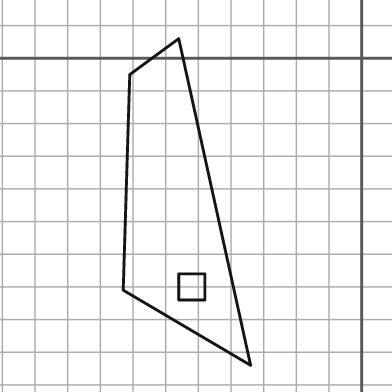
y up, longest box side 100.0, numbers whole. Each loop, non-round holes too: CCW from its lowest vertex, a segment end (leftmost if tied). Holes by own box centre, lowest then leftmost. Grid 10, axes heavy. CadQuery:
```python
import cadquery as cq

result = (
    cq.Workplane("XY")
    .moveTo(-34.0, -94.0)
    .lineTo(-56.0, 6.0)
    .lineTo(-71.0, -5.0)
    .lineTo(-73.0, -71.0)
    .close()
    .moveTo(-56.0, -74.0)
    .lineTo(-48.0, -74.0)
    .lineTo(-48.0, -66.0)
    .lineTo(-56.0, -66.0)
    .close()
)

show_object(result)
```